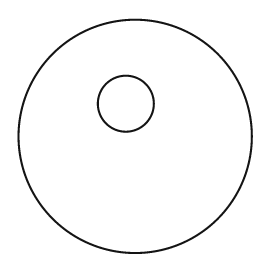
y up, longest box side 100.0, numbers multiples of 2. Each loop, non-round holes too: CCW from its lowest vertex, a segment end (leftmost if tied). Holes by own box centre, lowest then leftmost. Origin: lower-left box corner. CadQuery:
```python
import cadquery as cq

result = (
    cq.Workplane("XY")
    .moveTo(50.0, 50.0)
    .circle(50.0)
    .moveTo(46.0, 64.0)
    .circle(12.0)
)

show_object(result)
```